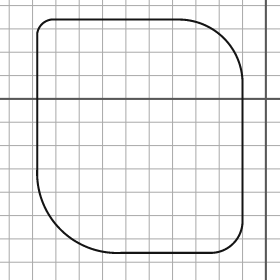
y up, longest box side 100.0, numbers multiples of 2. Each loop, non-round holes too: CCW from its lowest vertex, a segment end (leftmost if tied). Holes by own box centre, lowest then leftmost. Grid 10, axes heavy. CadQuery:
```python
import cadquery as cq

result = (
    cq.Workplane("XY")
    .moveTo(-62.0, -66.0)
    .lineTo(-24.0, -66.0)
    .threePointArc((-14.0, -62.0), (-10.0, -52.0))
    .lineTo(-10.0, 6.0)
    .threePointArc((-18.0, 26.0), (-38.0, 34.0))
    .lineTo(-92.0, 34.0)
    .threePointArc((-96.0, 32.0), (-98.0, 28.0))
    .lineTo(-98.0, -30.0)
    .threePointArc((-88.0, -56.0), (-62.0, -66.0))
    .close()
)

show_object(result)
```